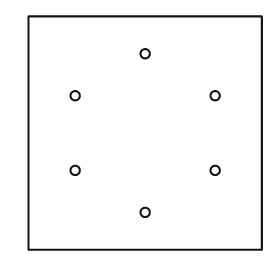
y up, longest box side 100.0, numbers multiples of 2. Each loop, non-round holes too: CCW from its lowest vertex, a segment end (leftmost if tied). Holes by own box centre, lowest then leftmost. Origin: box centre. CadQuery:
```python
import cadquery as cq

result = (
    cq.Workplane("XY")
    .moveTo(-50.0, -50.0)
    .lineTo(50.0, -50.0)
    .lineTo(50.0, 50.0)
    .lineTo(-50.0, 50.0)
    .close()
    .moveTo(0.0, -34.0)
    .circle(2.0)
    .moveTo(-30.0, -16.0)
    .circle(2.0)
    .moveTo(30.0, -16.0)
    .circle(2.0)
    .moveTo(-30.0, 16.0)
    .circle(2.0)
    .moveTo(30.0, 16.0)
    .circle(2.0)
    .moveTo(0.0, 34.0)
    .circle(2.0)
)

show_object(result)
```